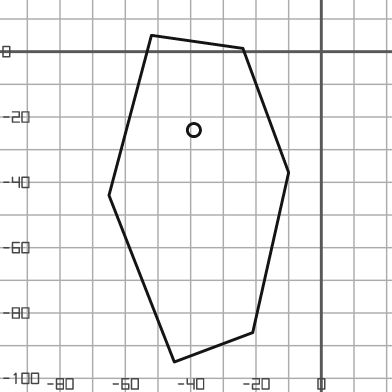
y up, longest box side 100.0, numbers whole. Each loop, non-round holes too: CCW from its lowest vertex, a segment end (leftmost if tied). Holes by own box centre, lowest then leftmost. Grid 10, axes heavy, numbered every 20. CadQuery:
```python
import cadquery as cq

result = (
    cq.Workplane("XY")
    .moveTo(-45.0, -95.0)
    .lineTo(-21.0, -86.0)
    .lineTo(-10.0, -37.0)
    .lineTo(-24.0, 1.0)
    .lineTo(-52.0, 5.0)
    .lineTo(-65.0, -44.0)
    .close()
    .moveTo(-39.0, -24.0)
    .circle(2.0)
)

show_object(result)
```